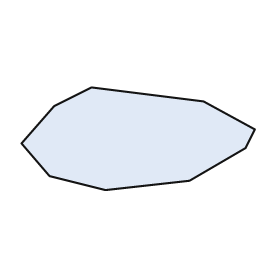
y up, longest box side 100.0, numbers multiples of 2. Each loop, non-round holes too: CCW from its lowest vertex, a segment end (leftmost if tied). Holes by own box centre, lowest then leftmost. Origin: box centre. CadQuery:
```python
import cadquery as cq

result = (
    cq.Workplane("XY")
    .moveTo(-14.0, -22.0)
    .lineTo(22.0, -18.0)
    .lineTo(46.0, -4.0)
    .lineTo(50.0, 4.0)
    .lineTo(28.0, 16.0)
    .lineTo(-20.0, 22.0)
    .lineTo(-36.0, 14.0)
    .lineTo(-50.0, -2.0)
    .lineTo(-38.0, -16.0)
    .close()
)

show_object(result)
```